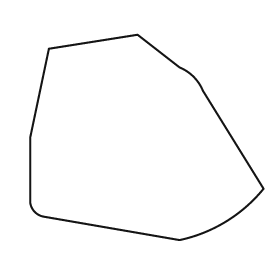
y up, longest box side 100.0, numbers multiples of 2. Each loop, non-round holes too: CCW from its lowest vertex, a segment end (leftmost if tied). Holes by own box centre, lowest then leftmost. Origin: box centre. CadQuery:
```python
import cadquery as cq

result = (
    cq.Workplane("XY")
    .moveTo(14.0, -44.0)
    .threePointArc((34.0, -36.0), (50.0, -22.0))
    .lineTo(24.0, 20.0)
    .threePointArc((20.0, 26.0), (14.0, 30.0))
    .lineTo(-4.0, 44.0)
    .lineTo(-42.0, 38.0)
    .lineTo(-50.0, 0.0)
    .lineTo(-50.0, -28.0)
    .threePointArc((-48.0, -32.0), (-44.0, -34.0))
    .close()
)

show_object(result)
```